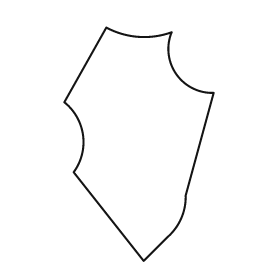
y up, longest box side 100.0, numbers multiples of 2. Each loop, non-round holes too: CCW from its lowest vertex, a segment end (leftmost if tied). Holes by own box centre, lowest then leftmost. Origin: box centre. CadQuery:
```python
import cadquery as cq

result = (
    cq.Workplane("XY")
    .moveTo(2.0, -50.0)
    .lineTo(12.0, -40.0)
    .threePointArc((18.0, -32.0), (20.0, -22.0))
    .lineTo(32.0, 22.0)
    .threePointArc((16.0, 30.0), (14.0, 48.0))
    .threePointArc((0.0, 46.0), (-14.0, 50.0))
    .lineTo(-32.0, 18.0)
    .threePointArc((-24.0, 4.0), (-28.0, -12.0))
    .close()
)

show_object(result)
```